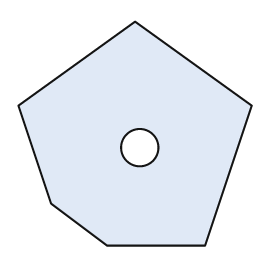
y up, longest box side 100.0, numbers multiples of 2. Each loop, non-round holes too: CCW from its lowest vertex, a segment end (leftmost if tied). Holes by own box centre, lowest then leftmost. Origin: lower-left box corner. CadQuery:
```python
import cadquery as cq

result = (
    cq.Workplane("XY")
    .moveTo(38.0, 0.0)
    .lineTo(80.0, 0.0)
    .lineTo(100.0, 60.0)
    .lineTo(50.0, 96.0)
    .lineTo(0.0, 60.0)
    .lineTo(14.0, 18.0)
    .close()
    .moveTo(52.0, 42.0)
    .circle(8.0)
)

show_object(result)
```